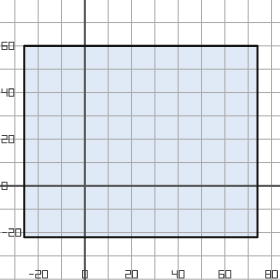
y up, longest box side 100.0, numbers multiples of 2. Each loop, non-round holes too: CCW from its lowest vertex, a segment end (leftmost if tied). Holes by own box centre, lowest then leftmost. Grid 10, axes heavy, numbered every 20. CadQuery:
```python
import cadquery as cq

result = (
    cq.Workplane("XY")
    .moveTo(-26.0, -22.0)
    .lineTo(74.0, -22.0)
    .lineTo(74.0, 60.0)
    .lineTo(-26.0, 60.0)
    .close()
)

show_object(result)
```